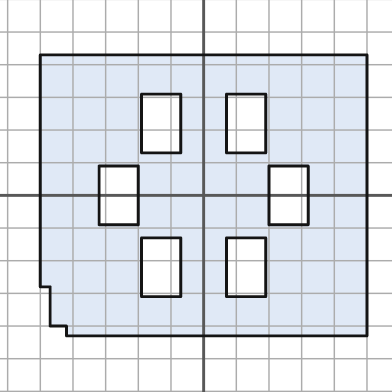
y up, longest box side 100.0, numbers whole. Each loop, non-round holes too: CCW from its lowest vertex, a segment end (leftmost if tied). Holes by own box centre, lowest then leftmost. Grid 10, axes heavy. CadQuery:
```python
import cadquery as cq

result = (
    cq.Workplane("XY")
    .moveTo(-42.0, -43.0)
    .lineTo(50.0, -43.0)
    .lineTo(50.0, 43.0)
    .lineTo(-50.0, 43.0)
    .lineTo(-50.0, -28.0)
    .lineTo(-47.0, -28.0)
    .lineTo(-47.0, -40.0)
    .lineTo(-42.0, -40.0)
    .close()
    .moveTo(-19.0, -31.0)
    .lineTo(-7.0, -31.0)
    .lineTo(-7.0, -13.0)
    .lineTo(-19.0, -13.0)
    .close()
    .moveTo(7.0, -31.0)
    .lineTo(19.0, -31.0)
    .lineTo(19.0, -13.0)
    .lineTo(7.0, -13.0)
    .close()
    .moveTo(-32.0, -9.0)
    .lineTo(-20.0, -9.0)
    .lineTo(-20.0, 9.0)
    .lineTo(-32.0, 9.0)
    .close()
    .moveTo(20.0, -9.0)
    .lineTo(32.0, -9.0)
    .lineTo(32.0, 9.0)
    .lineTo(20.0, 9.0)
    .close()
    .moveTo(-19.0, 13.0)
    .lineTo(-7.0, 13.0)
    .lineTo(-7.0, 31.0)
    .lineTo(-19.0, 31.0)
    .close()
    .moveTo(7.0, 13.0)
    .lineTo(19.0, 13.0)
    .lineTo(19.0, 31.0)
    .lineTo(7.0, 31.0)
    .close()
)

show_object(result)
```